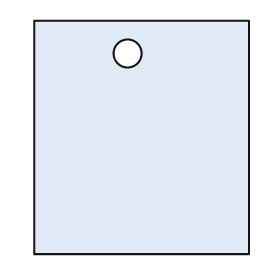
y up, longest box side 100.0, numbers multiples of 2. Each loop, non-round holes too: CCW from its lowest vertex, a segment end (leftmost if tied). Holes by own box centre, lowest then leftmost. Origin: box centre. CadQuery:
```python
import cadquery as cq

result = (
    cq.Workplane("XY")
    .moveTo(-46.0, -50.0)
    .lineTo(46.0, -50.0)
    .lineTo(46.0, 50.0)
    .lineTo(-46.0, 50.0)
    .close()
    .moveTo(-6.0, 36.0)
    .circle(6.0)
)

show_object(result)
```